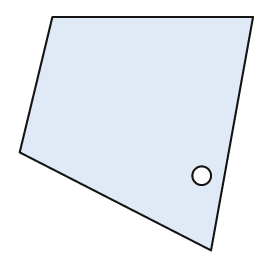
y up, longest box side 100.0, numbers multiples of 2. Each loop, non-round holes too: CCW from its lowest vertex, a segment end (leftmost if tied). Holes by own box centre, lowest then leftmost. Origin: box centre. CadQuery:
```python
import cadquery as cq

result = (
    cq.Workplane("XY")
    .moveTo(32.0, -50.0)
    .lineTo(50.0, 50.0)
    .lineTo(-36.0, 50.0)
    .lineTo(-50.0, -8.0)
    .close()
    .moveTo(28.0, -18.0)
    .circle(4.0)
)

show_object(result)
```